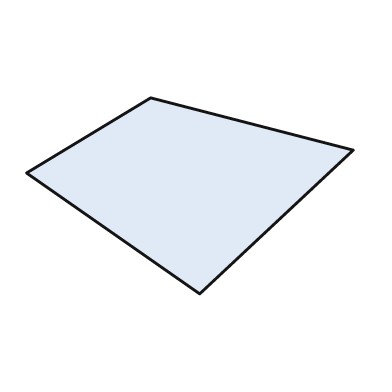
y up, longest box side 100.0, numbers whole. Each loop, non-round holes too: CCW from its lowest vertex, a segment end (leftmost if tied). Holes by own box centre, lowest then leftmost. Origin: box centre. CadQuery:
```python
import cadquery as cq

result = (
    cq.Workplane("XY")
    .moveTo(3.0, -30.0)
    .lineTo(50.0, 14.0)
    .lineTo(-12.0, 30.0)
    .lineTo(-50.0, 7.0)
    .close()
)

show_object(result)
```